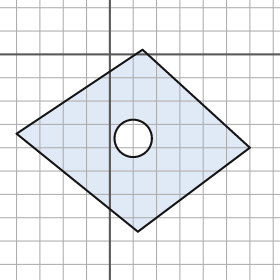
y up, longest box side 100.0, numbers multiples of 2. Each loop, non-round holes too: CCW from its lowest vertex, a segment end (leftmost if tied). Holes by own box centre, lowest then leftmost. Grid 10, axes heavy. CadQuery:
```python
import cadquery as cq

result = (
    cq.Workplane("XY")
    .moveTo(12.0, -76.0)
    .lineTo(60.0, -40.0)
    .lineTo(14.0, 2.0)
    .lineTo(-40.0, -34.0)
    .close()
    .moveTo(10.0, -36.0)
    .circle(8.0)
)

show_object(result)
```